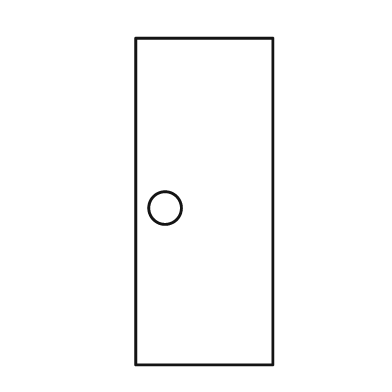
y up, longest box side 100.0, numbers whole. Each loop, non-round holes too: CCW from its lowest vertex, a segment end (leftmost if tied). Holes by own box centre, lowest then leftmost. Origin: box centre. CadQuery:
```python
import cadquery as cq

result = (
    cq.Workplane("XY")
    .moveTo(-21.0, -50.0)
    .lineTo(21.0, -50.0)
    .lineTo(21.0, 50.0)
    .lineTo(-21.0, 50.0)
    .close()
    .moveTo(-12.0, -2.0)
    .circle(5.0)
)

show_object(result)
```